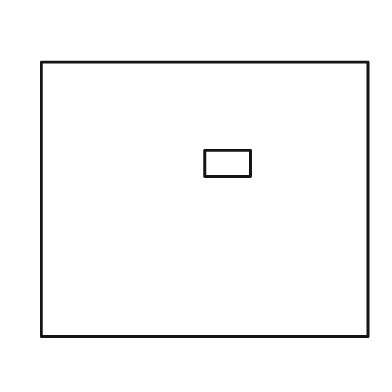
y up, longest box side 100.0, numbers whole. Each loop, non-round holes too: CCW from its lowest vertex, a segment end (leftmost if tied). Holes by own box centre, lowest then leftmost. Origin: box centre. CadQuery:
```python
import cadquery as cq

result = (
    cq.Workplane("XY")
    .moveTo(-50.0, -42.0)
    .lineTo(50.0, -42.0)
    .lineTo(50.0, 42.0)
    .lineTo(-50.0, 42.0)
    .close()
    .moveTo(0.0, 7.0)
    .lineTo(14.0, 7.0)
    .lineTo(14.0, 15.0)
    .lineTo(0.0, 15.0)
    .close()
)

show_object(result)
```